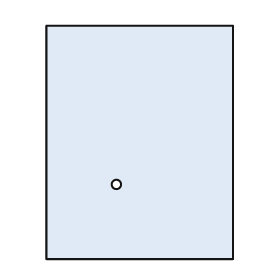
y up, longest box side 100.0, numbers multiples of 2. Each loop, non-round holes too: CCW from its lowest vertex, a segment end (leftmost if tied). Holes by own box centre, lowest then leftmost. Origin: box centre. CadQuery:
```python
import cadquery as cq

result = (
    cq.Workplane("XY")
    .moveTo(-40.0, -50.0)
    .lineTo(40.0, -50.0)
    .lineTo(40.0, 50.0)
    .lineTo(-40.0, 50.0)
    .close()
    .moveTo(-10.0, -18.0)
    .circle(2.0)
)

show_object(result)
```